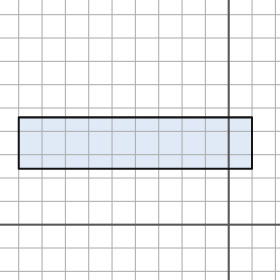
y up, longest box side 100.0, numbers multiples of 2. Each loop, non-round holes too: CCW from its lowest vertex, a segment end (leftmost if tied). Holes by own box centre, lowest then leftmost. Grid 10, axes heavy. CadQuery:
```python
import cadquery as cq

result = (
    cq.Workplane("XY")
    .moveTo(-90.0, 24.0)
    .lineTo(10.0, 24.0)
    .lineTo(10.0, 46.0)
    .lineTo(-90.0, 46.0)
    .close()
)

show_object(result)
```